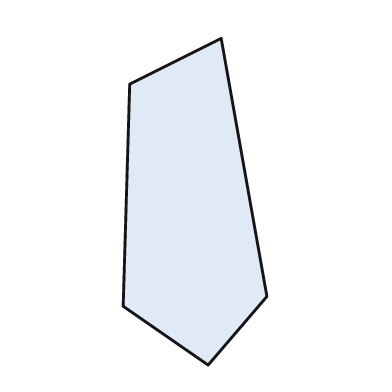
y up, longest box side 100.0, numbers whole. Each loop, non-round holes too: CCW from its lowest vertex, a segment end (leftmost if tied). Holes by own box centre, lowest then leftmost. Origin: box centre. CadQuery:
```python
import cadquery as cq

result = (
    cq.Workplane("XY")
    .moveTo(4.0, -50.0)
    .lineTo(22.0, -29.0)
    .lineTo(8.0, 50.0)
    .lineTo(-20.0, 36.0)
    .lineTo(-22.0, -32.0)
    .close()
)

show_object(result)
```